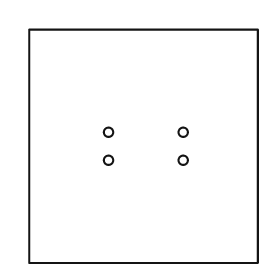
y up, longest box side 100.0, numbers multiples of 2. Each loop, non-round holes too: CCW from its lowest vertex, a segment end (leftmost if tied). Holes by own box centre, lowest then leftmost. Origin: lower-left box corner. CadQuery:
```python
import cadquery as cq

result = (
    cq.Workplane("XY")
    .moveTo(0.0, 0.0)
    .lineTo(98.0, 0.0)
    .lineTo(98.0, 100.0)
    .lineTo(0.0, 100.0)
    .close()
    .moveTo(34.0, 44.0)
    .circle(2.0)
    .moveTo(66.0, 44.0)
    .circle(2.0)
    .moveTo(34.0, 56.0)
    .circle(2.0)
    .moveTo(66.0, 56.0)
    .circle(2.0)
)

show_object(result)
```